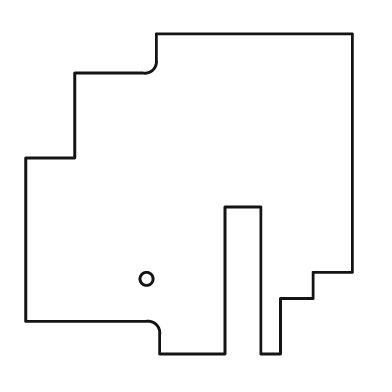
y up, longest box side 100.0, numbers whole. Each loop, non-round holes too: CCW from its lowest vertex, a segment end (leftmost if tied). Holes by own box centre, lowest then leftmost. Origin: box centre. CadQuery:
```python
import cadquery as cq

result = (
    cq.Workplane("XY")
    .moveTo(-9.0, -49.0)
    .lineTo(11.0, -49.0)
    .lineTo(11.0, -4.0)
    .lineTo(22.0, -4.0)
    .lineTo(22.0, -49.0)
    .lineTo(28.0, -49.0)
    .lineTo(28.0, -32.0)
    .lineTo(38.0, -32.0)
    .lineTo(38.0, -24.0)
    .lineTo(50.0, -24.0)
    .lineTo(50.0, 49.0)
    .lineTo(-10.0, 49.0)
    .lineTo(-10.0, 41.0)
    .threePointArc((-11.0, 38.0), (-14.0, 37.0))
    .lineTo(-35.0, 37.0)
    .lineTo(-35.0, 11.0)
    .lineTo(-50.0, 11.0)
    .lineTo(-50.0, -39.0)
    .lineTo(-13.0, -39.0)
    .threePointArc((-10.0, -40.0), (-9.0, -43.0))
    .close()
    .moveTo(-13.0, -26.0)
    .circle(2.0)
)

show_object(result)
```